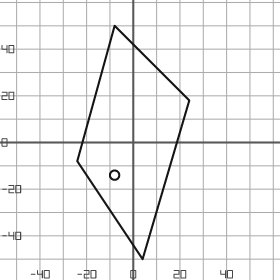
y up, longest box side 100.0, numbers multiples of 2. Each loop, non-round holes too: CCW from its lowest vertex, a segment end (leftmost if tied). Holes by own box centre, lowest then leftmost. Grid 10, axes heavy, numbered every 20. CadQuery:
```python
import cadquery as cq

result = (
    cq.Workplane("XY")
    .moveTo(4.0, -50.0)
    .lineTo(24.0, 18.0)
    .lineTo(-8.0, 50.0)
    .lineTo(-24.0, -8.0)
    .close()
    .moveTo(-8.0, -14.0)
    .circle(2.0)
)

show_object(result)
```